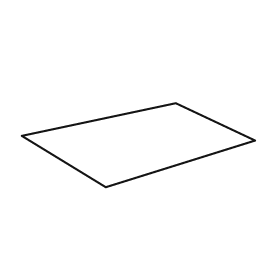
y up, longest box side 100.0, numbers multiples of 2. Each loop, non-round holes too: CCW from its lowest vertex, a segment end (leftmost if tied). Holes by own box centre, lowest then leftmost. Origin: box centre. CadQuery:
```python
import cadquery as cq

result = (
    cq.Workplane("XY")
    .moveTo(-14.0, -18.0)
    .lineTo(50.0, 2.0)
    .lineTo(16.0, 18.0)
    .lineTo(-50.0, 4.0)
    .close()
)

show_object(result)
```